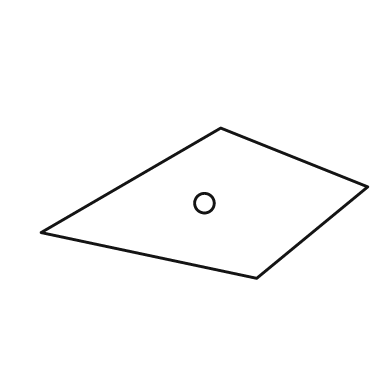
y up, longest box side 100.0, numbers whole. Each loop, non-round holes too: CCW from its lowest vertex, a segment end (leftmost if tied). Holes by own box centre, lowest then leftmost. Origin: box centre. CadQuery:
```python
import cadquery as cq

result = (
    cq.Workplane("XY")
    .moveTo(16.0, -23.0)
    .lineTo(50.0, 5.0)
    .lineTo(5.0, 23.0)
    .lineTo(-50.0, -9.0)
    .close()
    .moveTo(0.0, 0.0)
    .circle(3.0)
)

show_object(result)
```